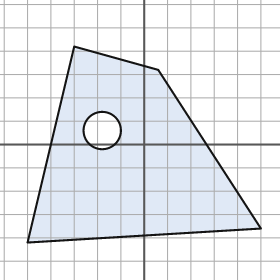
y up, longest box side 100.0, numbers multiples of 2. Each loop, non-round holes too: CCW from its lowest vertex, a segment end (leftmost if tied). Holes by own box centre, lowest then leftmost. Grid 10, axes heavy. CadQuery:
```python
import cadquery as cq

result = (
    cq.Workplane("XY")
    .moveTo(-50.0, -42.0)
    .lineTo(50.0, -36.0)
    .lineTo(6.0, 32.0)
    .lineTo(-30.0, 42.0)
    .close()
    .moveTo(-18.0, 6.0)
    .circle(8.0)
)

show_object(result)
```